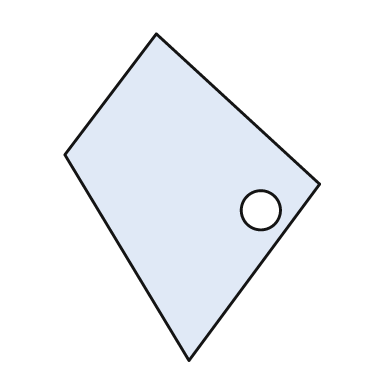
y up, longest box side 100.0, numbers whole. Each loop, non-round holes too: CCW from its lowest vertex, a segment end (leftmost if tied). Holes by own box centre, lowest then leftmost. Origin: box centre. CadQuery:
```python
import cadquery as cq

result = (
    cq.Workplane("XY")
    .moveTo(-1.0, -50.0)
    .lineTo(39.0, 4.0)
    .lineTo(-11.0, 50.0)
    .lineTo(-39.0, 13.0)
    .close()
    .moveTo(21.0, -4.0)
    .circle(6.0)
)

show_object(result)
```